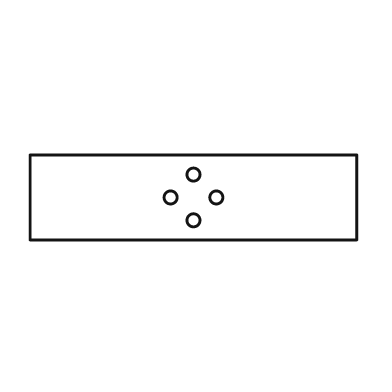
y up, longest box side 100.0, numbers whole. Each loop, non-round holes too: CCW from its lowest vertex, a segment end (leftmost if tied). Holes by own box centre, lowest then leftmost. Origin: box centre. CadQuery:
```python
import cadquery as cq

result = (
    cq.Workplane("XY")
    .moveTo(-50.0, -13.0)
    .lineTo(50.0, -13.0)
    .lineTo(50.0, 13.0)
    .lineTo(-50.0, 13.0)
    .close()
    .moveTo(0.0, -7.0)
    .circle(2.0)
    .moveTo(-7.0, 0.0)
    .circle(2.0)
    .moveTo(7.0, 0.0)
    .circle(2.0)
    .moveTo(0.0, 7.0)
    .circle(2.0)
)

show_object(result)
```